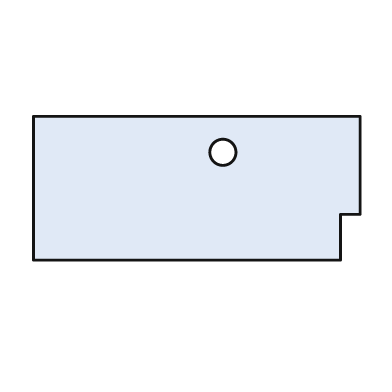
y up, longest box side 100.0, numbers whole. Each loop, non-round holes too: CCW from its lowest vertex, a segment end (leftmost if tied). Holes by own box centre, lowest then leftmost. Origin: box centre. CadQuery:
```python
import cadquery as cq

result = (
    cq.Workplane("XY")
    .moveTo(-50.0, -22.0)
    .lineTo(44.0, -22.0)
    .lineTo(44.0, -8.0)
    .lineTo(50.0, -8.0)
    .lineTo(50.0, 22.0)
    .lineTo(-50.0, 22.0)
    .close()
    .moveTo(8.0, 11.0)
    .circle(4.0)
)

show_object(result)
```